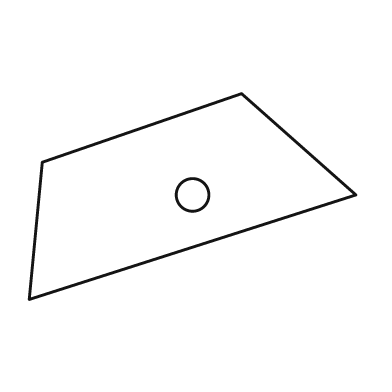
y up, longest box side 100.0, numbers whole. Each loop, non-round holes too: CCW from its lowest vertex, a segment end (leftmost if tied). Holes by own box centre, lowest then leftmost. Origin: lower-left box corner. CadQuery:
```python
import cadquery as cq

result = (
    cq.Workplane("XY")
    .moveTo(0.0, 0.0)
    .lineTo(100.0, 32.0)
    .lineTo(65.0, 63.0)
    .lineTo(4.0, 42.0)
    .close()
    .moveTo(50.0, 32.0)
    .circle(5.0)
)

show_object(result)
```